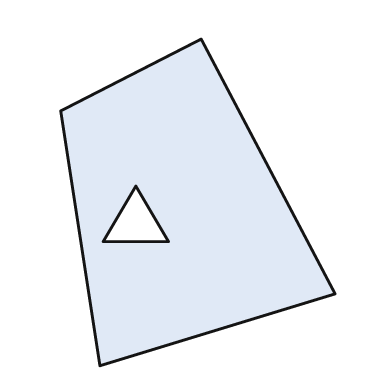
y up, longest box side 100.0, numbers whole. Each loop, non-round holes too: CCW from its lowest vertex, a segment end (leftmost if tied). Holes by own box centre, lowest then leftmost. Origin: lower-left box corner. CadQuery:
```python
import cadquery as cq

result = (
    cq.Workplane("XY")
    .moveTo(12.0, 0.0)
    .lineTo(84.0, 22.0)
    .lineTo(43.0, 100.0)
    .lineTo(0.0, 78.0)
    .close()
    .moveTo(13.0, 38.0)
    .lineTo(33.0, 38.0)
    .lineTo(23.0, 55.0)
    .close()
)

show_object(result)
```